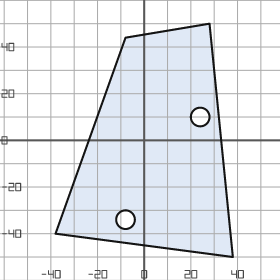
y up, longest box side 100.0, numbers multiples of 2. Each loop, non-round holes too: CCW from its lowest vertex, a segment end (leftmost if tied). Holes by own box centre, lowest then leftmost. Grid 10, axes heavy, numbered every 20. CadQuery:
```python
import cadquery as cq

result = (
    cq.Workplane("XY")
    .moveTo(38.0, -50.0)
    .lineTo(28.0, 50.0)
    .lineTo(-8.0, 44.0)
    .lineTo(-38.0, -40.0)
    .close()
    .moveTo(-8.0, -34.0)
    .circle(4.0)
    .moveTo(24.0, 10.0)
    .circle(4.0)
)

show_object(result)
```